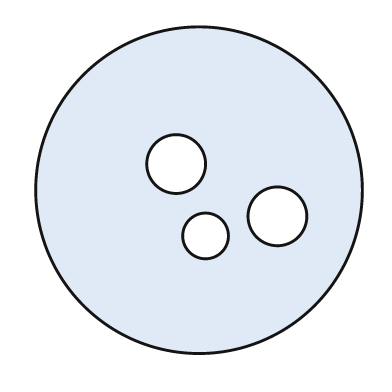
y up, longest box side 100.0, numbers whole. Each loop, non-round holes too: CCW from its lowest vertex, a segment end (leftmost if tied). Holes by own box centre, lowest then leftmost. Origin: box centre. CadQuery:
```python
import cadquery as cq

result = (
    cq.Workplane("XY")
    .moveTo(0.0, 0.0)
    .circle(50.0)
    .moveTo(2.0, -14.0)
    .circle(7.0)
    .moveTo(24.0, -8.0)
    .circle(9.0)
    .moveTo(-7.0, 8.0)
    .circle(9.0)
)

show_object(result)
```